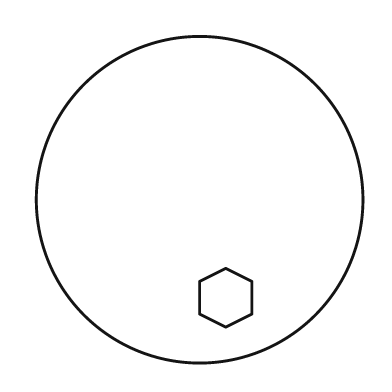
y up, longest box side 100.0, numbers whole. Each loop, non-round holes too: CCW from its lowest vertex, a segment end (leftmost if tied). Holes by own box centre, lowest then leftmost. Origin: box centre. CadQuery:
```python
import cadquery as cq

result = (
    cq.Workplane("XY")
    .moveTo(0.0, 0.0)
    .circle(50.0)
    .moveTo(8.0, -39.0)
    .lineTo(16.0, -35.0)
    .lineTo(16.0, -25.0)
    .lineTo(8.0, -21.0)
    .lineTo(0.0, -25.0)
    .lineTo(0.0, -35.0)
    .close()
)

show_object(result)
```